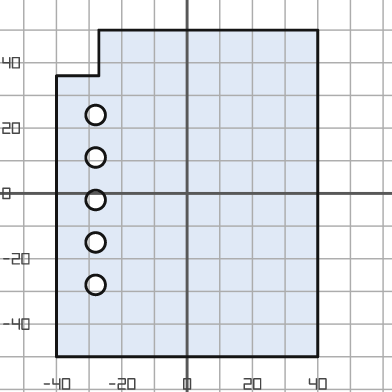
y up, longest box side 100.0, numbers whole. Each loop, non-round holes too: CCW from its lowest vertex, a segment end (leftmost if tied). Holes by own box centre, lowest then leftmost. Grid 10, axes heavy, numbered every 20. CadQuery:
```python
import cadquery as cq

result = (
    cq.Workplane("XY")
    .moveTo(-40.0, -50.0)
    .lineTo(40.0, -50.0)
    .lineTo(40.0, 50.0)
    .lineTo(-27.0, 50.0)
    .lineTo(-27.0, 36.0)
    .lineTo(-40.0, 36.0)
    .close()
    .moveTo(-28.0, -28.0)
    .circle(3.0)
    .moveTo(-28.0, -15.0)
    .circle(3.0)
    .moveTo(-28.0, -2.0)
    .circle(3.0)
    .moveTo(-28.0, 11.0)
    .circle(3.0)
    .moveTo(-28.0, 24.0)
    .circle(3.0)
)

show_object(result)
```